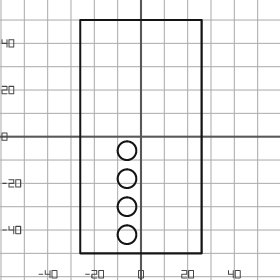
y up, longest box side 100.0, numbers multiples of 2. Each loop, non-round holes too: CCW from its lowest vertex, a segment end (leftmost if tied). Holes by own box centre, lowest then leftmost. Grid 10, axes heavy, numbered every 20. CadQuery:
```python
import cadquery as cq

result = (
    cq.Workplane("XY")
    .moveTo(-26.0, -50.0)
    .lineTo(26.0, -50.0)
    .lineTo(26.0, 50.0)
    .lineTo(-26.0, 50.0)
    .close()
    .moveTo(-6.0, -42.0)
    .circle(4.0)
    .moveTo(-6.0, -30.0)
    .circle(4.0)
    .moveTo(-6.0, -18.0)
    .circle(4.0)
    .moveTo(-6.0, -6.0)
    .circle(4.0)
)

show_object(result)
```